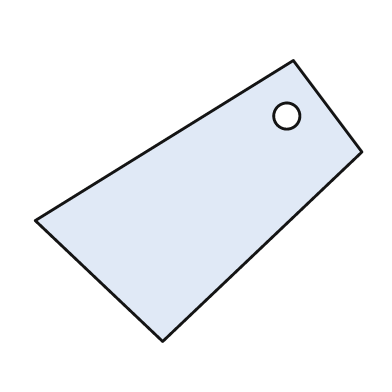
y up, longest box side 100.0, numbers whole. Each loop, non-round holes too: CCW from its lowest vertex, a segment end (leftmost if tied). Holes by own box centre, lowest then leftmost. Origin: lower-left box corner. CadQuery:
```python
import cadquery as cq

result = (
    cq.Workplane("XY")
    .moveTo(39.0, 0.0)
    .lineTo(100.0, 58.0)
    .lineTo(79.0, 86.0)
    .lineTo(0.0, 37.0)
    .close()
    .moveTo(77.0, 69.0)
    .circle(4.0)
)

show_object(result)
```